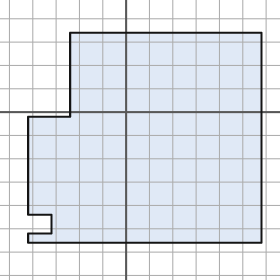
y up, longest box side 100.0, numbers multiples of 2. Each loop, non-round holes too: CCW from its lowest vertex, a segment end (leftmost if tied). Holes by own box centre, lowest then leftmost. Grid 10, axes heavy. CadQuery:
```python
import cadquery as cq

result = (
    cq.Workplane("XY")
    .moveTo(-42.0, -56.0)
    .lineTo(58.0, -56.0)
    .lineTo(58.0, 34.0)
    .lineTo(-24.0, 34.0)
    .lineTo(-24.0, -2.0)
    .lineTo(-42.0, -2.0)
    .lineTo(-42.0, -44.0)
    .lineTo(-32.0, -44.0)
    .lineTo(-32.0, -52.0)
    .lineTo(-42.0, -52.0)
    .close()
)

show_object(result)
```